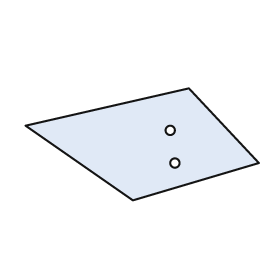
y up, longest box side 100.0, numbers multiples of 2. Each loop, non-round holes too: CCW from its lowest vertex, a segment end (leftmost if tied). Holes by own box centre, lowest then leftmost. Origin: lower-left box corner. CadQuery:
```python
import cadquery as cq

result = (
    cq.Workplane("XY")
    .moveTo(46.0, 0.0)
    .lineTo(100.0, 16.0)
    .lineTo(70.0, 48.0)
    .lineTo(0.0, 32.0)
    .close()
    .moveTo(64.0, 16.0)
    .circle(2.0)
    .moveTo(62.0, 30.0)
    .circle(2.0)
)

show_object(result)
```